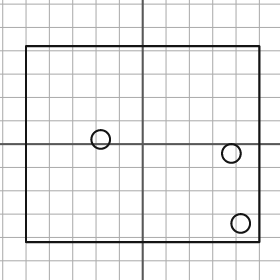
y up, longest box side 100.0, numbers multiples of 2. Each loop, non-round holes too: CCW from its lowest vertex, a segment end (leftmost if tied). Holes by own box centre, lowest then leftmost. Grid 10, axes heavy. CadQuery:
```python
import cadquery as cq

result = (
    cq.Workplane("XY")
    .moveTo(-50.0, -42.0)
    .lineTo(50.0, -42.0)
    .lineTo(50.0, 42.0)
    .lineTo(-50.0, 42.0)
    .close()
    .moveTo(42.0, -34.0)
    .circle(4.0)
    .moveTo(38.0, -4.0)
    .circle(4.0)
    .moveTo(-18.0, 2.0)
    .circle(4.0)
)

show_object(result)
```